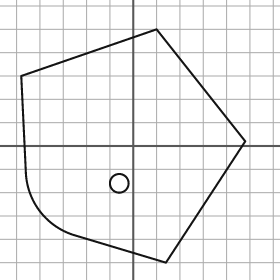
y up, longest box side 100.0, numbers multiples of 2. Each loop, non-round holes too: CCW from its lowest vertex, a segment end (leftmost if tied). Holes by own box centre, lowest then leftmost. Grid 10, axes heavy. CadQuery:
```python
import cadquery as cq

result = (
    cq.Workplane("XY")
    .moveTo(14.0, -50.0)
    .lineTo(48.0, 2.0)
    .lineTo(10.0, 50.0)
    .lineTo(-48.0, 30.0)
    .lineTo(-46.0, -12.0)
    .threePointArc((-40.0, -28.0), (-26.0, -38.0))
    .close()
    .moveTo(-6.0, -16.0)
    .circle(4.0)
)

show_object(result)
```